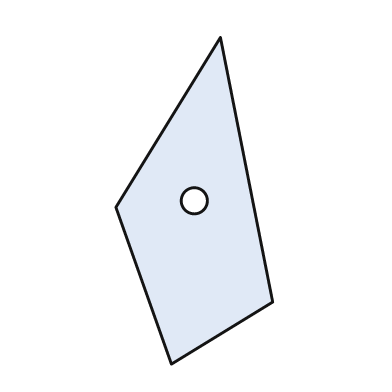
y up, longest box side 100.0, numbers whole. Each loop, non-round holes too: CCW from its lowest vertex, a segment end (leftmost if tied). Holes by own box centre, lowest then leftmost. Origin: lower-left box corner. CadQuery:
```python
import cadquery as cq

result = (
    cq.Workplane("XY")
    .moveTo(17.0, 0.0)
    .lineTo(48.0, 19.0)
    .lineTo(32.0, 100.0)
    .lineTo(0.0, 48.0)
    .close()
    .moveTo(24.0, 50.0)
    .circle(4.0)
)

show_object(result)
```